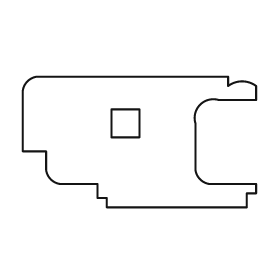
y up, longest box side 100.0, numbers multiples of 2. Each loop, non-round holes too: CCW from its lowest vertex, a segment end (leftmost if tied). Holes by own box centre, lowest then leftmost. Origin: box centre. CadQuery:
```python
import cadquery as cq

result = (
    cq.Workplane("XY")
    .moveTo(-14.0, -28.0)
    .lineTo(46.0, -28.0)
    .lineTo(46.0, -22.0)
    .lineTo(50.0, -22.0)
    .lineTo(50.0, -18.0)
    .lineTo(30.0, -18.0)
    .threePointArc((26.0, -16.0), (24.0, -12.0))
    .lineTo(24.0, 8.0)
    .threePointArc((26.0, 16.0), (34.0, 18.0))
    .lineTo(50.0, 18.0)
    .lineTo(50.0, 24.0)
    .threePointArc((44.0, 26.0), (38.0, 24.0))
    .lineTo(38.0, 28.0)
    .lineTo(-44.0, 28.0)
    .threePointArc((-48.0, 26.0), (-50.0, 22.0))
    .lineTo(-50.0, -4.0)
    .lineTo(-40.0, -4.0)
    .lineTo(-40.0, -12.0)
    .threePointArc((-38.0, -16.0), (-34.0, -18.0))
    .lineTo(-18.0, -18.0)
    .lineTo(-18.0, -24.0)
    .lineTo(-14.0, -24.0)
    .close()
    .moveTo(-12.0, 2.0)
    .lineTo(0.0, 2.0)
    .lineTo(0.0, 14.0)
    .lineTo(-12.0, 14.0)
    .close()
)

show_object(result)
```